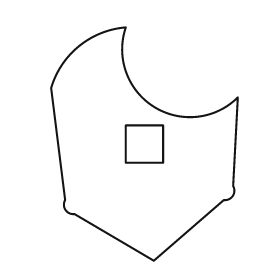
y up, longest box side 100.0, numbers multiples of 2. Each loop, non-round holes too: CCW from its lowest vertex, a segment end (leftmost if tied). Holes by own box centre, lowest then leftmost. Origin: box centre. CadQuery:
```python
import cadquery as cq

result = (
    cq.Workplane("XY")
    .moveTo(4.0, -50.0)
    .lineTo(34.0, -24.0)
    .threePointArc((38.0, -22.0), (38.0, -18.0))
    .lineTo(40.0, 20.0)
    .threePointArc((4.0, 16.0), (-8.0, 50.0))
    .threePointArc((-28.0, 42.0), (-40.0, 24.0))
    .lineTo(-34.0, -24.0)
    .threePointArc((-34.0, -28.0), (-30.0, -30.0))
    .close()
    .moveTo(-8.0, -8.0)
    .lineTo(8.0, -8.0)
    .lineTo(8.0, 8.0)
    .lineTo(-8.0, 8.0)
    .close()
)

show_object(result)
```